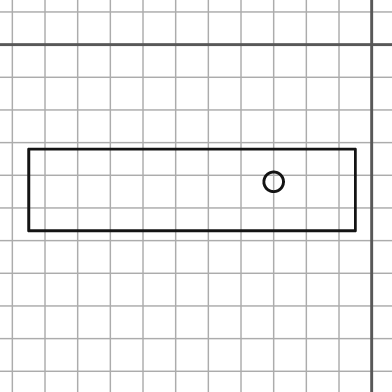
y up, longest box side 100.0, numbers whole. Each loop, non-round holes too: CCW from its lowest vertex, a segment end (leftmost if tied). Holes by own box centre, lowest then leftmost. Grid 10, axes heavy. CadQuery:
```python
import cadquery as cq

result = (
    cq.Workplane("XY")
    .moveTo(-105.0, -57.0)
    .lineTo(-5.0, -57.0)
    .lineTo(-5.0, -32.0)
    .lineTo(-105.0, -32.0)
    .close()
    .moveTo(-30.0, -42.0)
    .circle(3.0)
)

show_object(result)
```